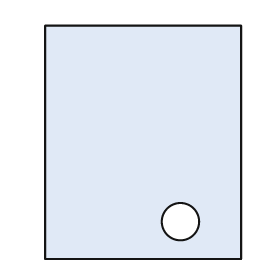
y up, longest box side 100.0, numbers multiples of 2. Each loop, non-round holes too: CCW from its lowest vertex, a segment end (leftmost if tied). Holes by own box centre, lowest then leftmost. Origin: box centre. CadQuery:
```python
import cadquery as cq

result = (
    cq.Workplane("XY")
    .moveTo(-42.0, -50.0)
    .lineTo(42.0, -50.0)
    .lineTo(42.0, 50.0)
    .lineTo(-42.0, 50.0)
    .close()
    .moveTo(16.0, -34.0)
    .circle(8.0)
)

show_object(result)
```